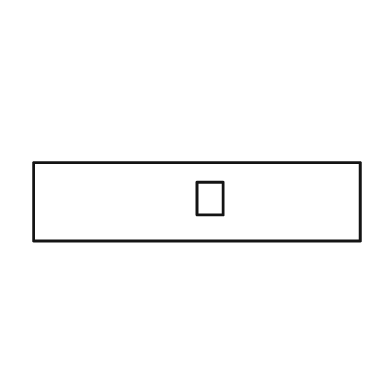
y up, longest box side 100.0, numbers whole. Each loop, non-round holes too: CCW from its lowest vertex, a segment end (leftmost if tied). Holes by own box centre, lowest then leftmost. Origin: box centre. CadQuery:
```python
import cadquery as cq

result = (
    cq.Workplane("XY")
    .moveTo(-50.0, -12.0)
    .lineTo(50.0, -12.0)
    .lineTo(50.0, 12.0)
    .lineTo(-50.0, 12.0)
    .close()
    .moveTo(0.0, -4.0)
    .lineTo(8.0, -4.0)
    .lineTo(8.0, 6.0)
    .lineTo(0.0, 6.0)
    .close()
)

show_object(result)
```